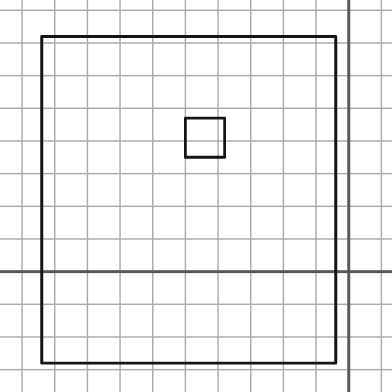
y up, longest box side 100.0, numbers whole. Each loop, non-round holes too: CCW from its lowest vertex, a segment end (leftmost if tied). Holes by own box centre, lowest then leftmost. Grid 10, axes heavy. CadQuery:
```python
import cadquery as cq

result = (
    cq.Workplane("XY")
    .moveTo(-94.0, -28.0)
    .lineTo(-4.0, -28.0)
    .lineTo(-4.0, 72.0)
    .lineTo(-94.0, 72.0)
    .close()
    .moveTo(-50.0, 35.0)
    .lineTo(-38.0, 35.0)
    .lineTo(-38.0, 47.0)
    .lineTo(-50.0, 47.0)
    .close()
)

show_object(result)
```